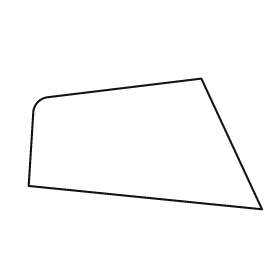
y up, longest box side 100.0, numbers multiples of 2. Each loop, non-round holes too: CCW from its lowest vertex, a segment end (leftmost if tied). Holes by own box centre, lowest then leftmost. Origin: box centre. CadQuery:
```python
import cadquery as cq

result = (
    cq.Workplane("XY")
    .moveTo(50.0, -28.0)
    .lineTo(24.0, 28.0)
    .lineTo(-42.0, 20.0)
    .threePointArc((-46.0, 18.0), (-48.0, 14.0))
    .lineTo(-50.0, -18.0)
    .close()
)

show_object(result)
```